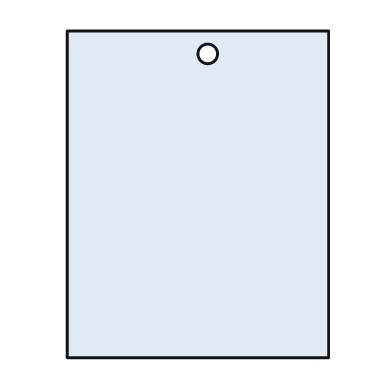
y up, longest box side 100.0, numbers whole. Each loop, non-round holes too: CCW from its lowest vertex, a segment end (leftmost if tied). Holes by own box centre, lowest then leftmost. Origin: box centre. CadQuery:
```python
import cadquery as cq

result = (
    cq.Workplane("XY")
    .moveTo(-40.0, -50.0)
    .lineTo(40.0, -50.0)
    .lineTo(40.0, 50.0)
    .lineTo(-40.0, 50.0)
    .close()
    .moveTo(3.0, 43.0)
    .circle(3.0)
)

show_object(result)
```